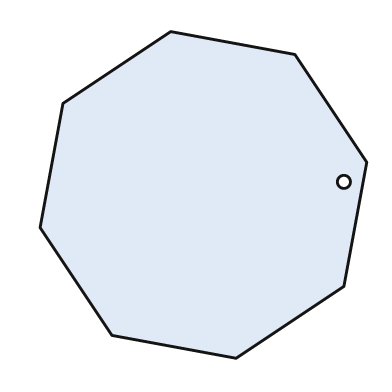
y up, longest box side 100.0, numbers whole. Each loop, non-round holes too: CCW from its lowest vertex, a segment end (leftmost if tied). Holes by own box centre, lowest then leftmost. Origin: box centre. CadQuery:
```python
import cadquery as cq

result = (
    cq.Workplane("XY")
    .moveTo(10.0, -50.0)
    .lineTo(43.0, -28.0)
    .lineTo(50.0, 10.0)
    .lineTo(28.0, 43.0)
    .lineTo(-10.0, 50.0)
    .lineTo(-43.0, 28.0)
    .lineTo(-50.0, -10.0)
    .lineTo(-28.0, -43.0)
    .close()
    .moveTo(43.0, 4.0)
    .circle(2.0)
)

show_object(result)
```